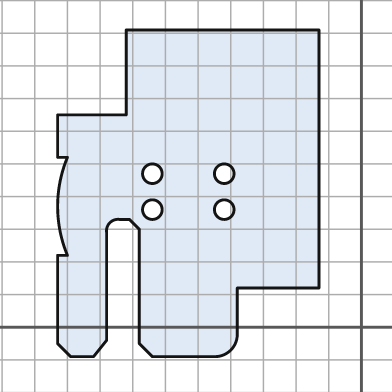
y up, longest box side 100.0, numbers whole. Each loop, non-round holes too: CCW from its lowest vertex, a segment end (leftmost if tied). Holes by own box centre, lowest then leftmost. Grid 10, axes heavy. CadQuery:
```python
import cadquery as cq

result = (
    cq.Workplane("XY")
    .moveTo(-89.0, -9.0)
    .lineTo(-82.0, -9.0)
    .lineTo(-78.0, -4.0)
    .lineTo(-78.0, 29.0)
    .threePointArc((-77.0, 32.0), (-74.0, 33.0))
    .lineTo(-71.0, 33.0)
    .lineTo(-68.0, 30.0)
    .lineTo(-68.0, -5.0)
    .lineTo(-64.0, -9.0)
    .lineTo(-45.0, -9.0)
    .threePointArc((-40.0, -7.0), (-38.0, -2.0))
    .lineTo(-38.0, 12.0)
    .lineTo(-13.0, 12.0)
    .lineTo(-13.0, 91.0)
    .lineTo(-72.0, 91.0)
    .lineTo(-72.0, 65.0)
    .lineTo(-93.0, 65.0)
    .lineTo(-93.0, 52.0)
    .lineTo(-90.0, 52.0)
    .threePointArc((-93.0, 37.0), (-90.0, 22.0))
    .lineTo(-93.0, 22.0)
    .lineTo(-93.0, -5.0)
    .close()
    .moveTo(-64.0, 36.0)
    .circle(3.0)
    .moveTo(-42.0, 36.0)
    .circle(3.0)
    .moveTo(-64.0, 47.0)
    .circle(3.0)
    .moveTo(-42.0, 47.0)
    .circle(3.0)
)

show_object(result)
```